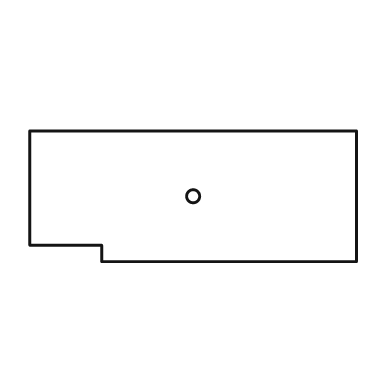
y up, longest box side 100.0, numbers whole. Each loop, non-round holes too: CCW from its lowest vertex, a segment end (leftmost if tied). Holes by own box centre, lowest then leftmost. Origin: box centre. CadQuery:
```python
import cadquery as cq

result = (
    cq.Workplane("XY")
    .moveTo(-28.0, -20.0)
    .lineTo(50.0, -20.0)
    .lineTo(50.0, 20.0)
    .lineTo(-50.0, 20.0)
    .lineTo(-50.0, -15.0)
    .lineTo(-28.0, -15.0)
    .close()
    .moveTo(0.0, 0.0)
    .circle(2.0)
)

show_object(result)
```